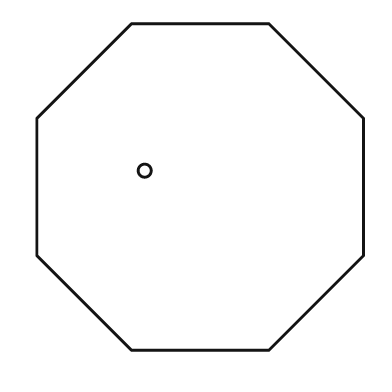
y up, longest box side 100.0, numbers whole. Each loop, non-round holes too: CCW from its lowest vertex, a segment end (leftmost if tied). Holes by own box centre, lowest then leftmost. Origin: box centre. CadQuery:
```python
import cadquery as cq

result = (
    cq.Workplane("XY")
    .moveTo(-21.0, -50.0)
    .lineTo(21.0, -50.0)
    .lineTo(50.0, -21.0)
    .lineTo(50.0, 21.0)
    .lineTo(21.0, 50.0)
    .lineTo(-21.0, 50.0)
    .lineTo(-50.0, 21.0)
    .lineTo(-50.0, -21.0)
    .close()
    .moveTo(-17.0, 5.0)
    .circle(2.0)
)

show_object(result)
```